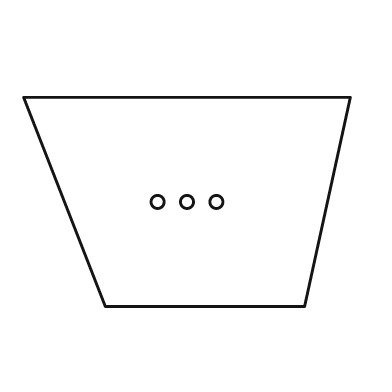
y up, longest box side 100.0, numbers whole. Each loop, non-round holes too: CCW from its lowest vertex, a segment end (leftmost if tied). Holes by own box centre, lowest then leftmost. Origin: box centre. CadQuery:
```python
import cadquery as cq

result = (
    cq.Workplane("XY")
    .moveTo(-25.0, -32.0)
    .lineTo(36.0, -32.0)
    .lineTo(50.0, 32.0)
    .lineTo(-50.0, 32.0)
    .close()
    .moveTo(-9.0, 0.0)
    .circle(2.0)
    .moveTo(0.0, 0.0)
    .circle(2.0)
    .moveTo(9.0, 0.0)
    .circle(2.0)
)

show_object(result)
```